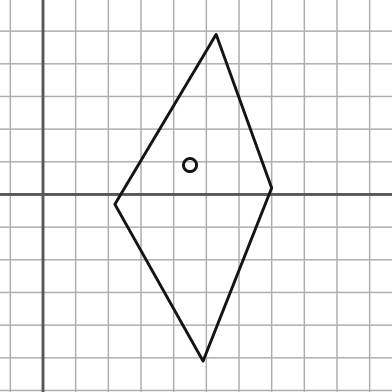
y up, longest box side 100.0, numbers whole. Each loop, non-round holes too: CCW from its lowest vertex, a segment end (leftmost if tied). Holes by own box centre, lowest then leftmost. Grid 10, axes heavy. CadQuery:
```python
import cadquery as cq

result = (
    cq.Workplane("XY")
    .moveTo(49.0, -51.0)
    .lineTo(70.0, 2.0)
    .lineTo(53.0, 49.0)
    .lineTo(22.0, -3.0)
    .close()
    .moveTo(45.0, 9.0)
    .circle(2.0)
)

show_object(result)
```